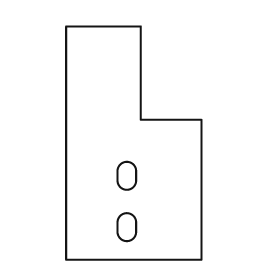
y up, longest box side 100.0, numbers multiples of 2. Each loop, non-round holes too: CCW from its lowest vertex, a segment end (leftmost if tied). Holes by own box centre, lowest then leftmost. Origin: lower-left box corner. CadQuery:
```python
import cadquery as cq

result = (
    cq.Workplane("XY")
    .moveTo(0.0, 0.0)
    .lineTo(58.0, 0.0)
    .lineTo(58.0, 60.0)
    .lineTo(32.0, 60.0)
    .lineTo(32.0, 100.0)
    .lineTo(0.0, 100.0)
    .close()
    .moveTo(22.0, 12.0)
    .threePointArc((26.0, 8.0), (30.0, 12.0))
    .lineTo(30.0, 16.0)
    .threePointArc((26.0, 20.0), (22.0, 16.0))
    .close()
    .moveTo(22.0, 34.0)
    .threePointArc((26.0, 30.0), (30.0, 34.0))
    .lineTo(30.0, 38.0)
    .threePointArc((26.0, 42.0), (22.0, 38.0))
    .close()
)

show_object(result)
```